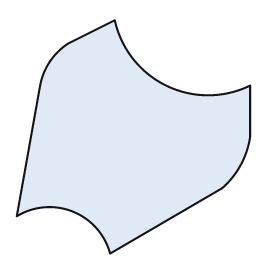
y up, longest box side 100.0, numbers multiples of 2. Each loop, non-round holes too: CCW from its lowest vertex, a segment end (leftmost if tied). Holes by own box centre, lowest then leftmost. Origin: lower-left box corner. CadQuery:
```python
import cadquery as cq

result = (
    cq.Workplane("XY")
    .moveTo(40.0, 0.0)
    .lineTo(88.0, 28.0)
    .threePointArc((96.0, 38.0), (100.0, 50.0))
    .lineTo(100.0, 72.0)
    .threePointArc((64.0, 72.0), (42.0, 100.0))
    .lineTo(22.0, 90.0)
    .threePointArc((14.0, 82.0), (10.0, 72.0))
    .lineTo(0.0, 16.0)
    .threePointArc((24.0, 18.0), (40.0, 0.0))
    .close()
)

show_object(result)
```